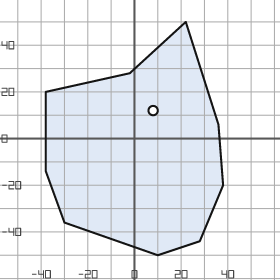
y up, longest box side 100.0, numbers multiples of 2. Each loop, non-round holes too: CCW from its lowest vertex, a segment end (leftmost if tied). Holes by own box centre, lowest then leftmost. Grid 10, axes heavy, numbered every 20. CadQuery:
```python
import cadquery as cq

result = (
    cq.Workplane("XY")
    .moveTo(10.0, -50.0)
    .lineTo(28.0, -44.0)
    .lineTo(38.0, -20.0)
    .lineTo(36.0, 6.0)
    .lineTo(22.0, 50.0)
    .lineTo(-2.0, 28.0)
    .lineTo(-38.0, 20.0)
    .lineTo(-38.0, -14.0)
    .lineTo(-30.0, -36.0)
    .close()
    .moveTo(8.0, 12.0)
    .circle(2.0)
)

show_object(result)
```